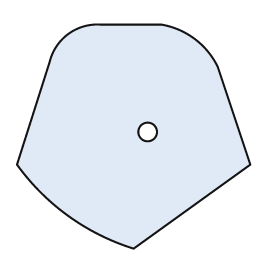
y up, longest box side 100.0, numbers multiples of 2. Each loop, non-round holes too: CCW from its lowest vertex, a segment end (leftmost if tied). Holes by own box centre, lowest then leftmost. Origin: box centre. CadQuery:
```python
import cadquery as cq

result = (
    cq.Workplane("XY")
    .moveTo(0.0, -48.0)
    .lineTo(50.0, -12.0)
    .lineTo(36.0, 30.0)
    .threePointArc((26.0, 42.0), (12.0, 48.0))
    .lineTo(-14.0, 48.0)
    .threePointArc((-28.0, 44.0), (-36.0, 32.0))
    .lineTo(-50.0, -12.0)
    .threePointArc((-28.0, -34.0), (0.0, -48.0))
    .close()
    .moveTo(6.0, 2.0)
    .circle(4.0)
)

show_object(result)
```